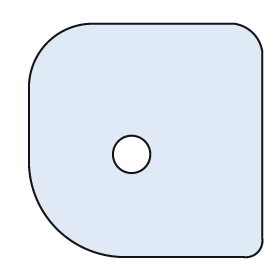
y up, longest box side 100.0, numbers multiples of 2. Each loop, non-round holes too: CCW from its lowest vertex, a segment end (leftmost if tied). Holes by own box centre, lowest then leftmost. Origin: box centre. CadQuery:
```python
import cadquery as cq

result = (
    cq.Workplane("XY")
    .moveTo(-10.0, -50.0)
    .lineTo(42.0, -50.0)
    .threePointArc((48.0, -48.0), (50.0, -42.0))
    .lineTo(50.0, 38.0)
    .threePointArc((46.0, 46.0), (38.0, 50.0))
    .lineTo(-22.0, 50.0)
    .threePointArc((-42.0, 42.0), (-50.0, 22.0))
    .lineTo(-50.0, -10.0)
    .threePointArc((-38.0, -38.0), (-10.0, -50.0))
    .close()
    .moveTo(-6.0, -6.0)
    .circle(8.0)
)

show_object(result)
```